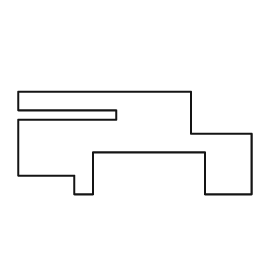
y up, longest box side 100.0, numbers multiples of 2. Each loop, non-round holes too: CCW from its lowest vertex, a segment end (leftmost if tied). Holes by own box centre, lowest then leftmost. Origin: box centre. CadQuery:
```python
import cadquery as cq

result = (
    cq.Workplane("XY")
    .moveTo(-26.0, -22.0)
    .lineTo(-18.0, -22.0)
    .lineTo(-18.0, -4.0)
    .lineTo(30.0, -4.0)
    .lineTo(30.0, -22.0)
    .lineTo(50.0, -22.0)
    .lineTo(50.0, 4.0)
    .lineTo(24.0, 4.0)
    .lineTo(24.0, 22.0)
    .lineTo(-50.0, 22.0)
    .lineTo(-50.0, 14.0)
    .lineTo(-8.0, 14.0)
    .lineTo(-8.0, 10.0)
    .lineTo(-50.0, 10.0)
    .lineTo(-50.0, -14.0)
    .lineTo(-26.0, -14.0)
    .close()
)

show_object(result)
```